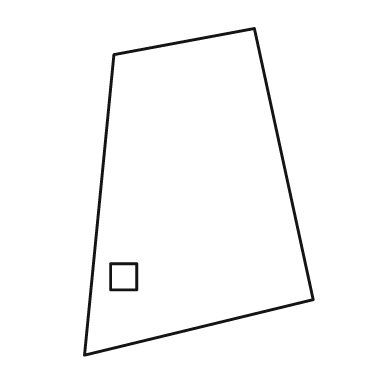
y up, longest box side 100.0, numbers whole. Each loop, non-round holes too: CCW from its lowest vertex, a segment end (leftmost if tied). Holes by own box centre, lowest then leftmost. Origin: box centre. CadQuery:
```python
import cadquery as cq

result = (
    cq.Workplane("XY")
    .moveTo(-35.0, -50.0)
    .lineTo(35.0, -33.0)
    .lineTo(17.0, 50.0)
    .lineTo(-26.0, 42.0)
    .close()
    .moveTo(-27.0, -30.0)
    .lineTo(-19.0, -30.0)
    .lineTo(-19.0, -22.0)
    .lineTo(-27.0, -22.0)
    .close()
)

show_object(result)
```